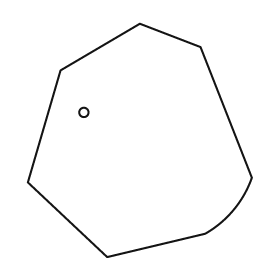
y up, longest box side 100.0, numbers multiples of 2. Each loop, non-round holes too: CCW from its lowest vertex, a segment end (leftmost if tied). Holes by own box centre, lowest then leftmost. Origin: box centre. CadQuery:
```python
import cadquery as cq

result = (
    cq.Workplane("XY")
    .moveTo(-14.0, -50.0)
    .lineTo(28.0, -40.0)
    .threePointArc((40.0, -30.0), (48.0, -16.0))
    .lineTo(26.0, 40.0)
    .lineTo(0.0, 50.0)
    .lineTo(-34.0, 30.0)
    .lineTo(-48.0, -18.0)
    .close()
    .moveTo(-24.0, 12.0)
    .circle(2.0)
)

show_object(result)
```